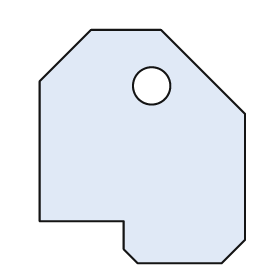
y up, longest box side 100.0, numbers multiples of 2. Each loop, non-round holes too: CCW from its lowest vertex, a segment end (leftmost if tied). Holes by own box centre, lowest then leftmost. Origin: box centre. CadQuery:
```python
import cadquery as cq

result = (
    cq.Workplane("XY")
    .moveTo(-2.0, -50.0)
    .lineTo(34.0, -50.0)
    .lineTo(44.0, -40.0)
    .lineTo(44.0, 14.0)
    .lineTo(8.0, 50.0)
    .lineTo(-22.0, 50.0)
    .lineTo(-44.0, 28.0)
    .lineTo(-44.0, -32.0)
    .lineTo(-8.0, -32.0)
    .lineTo(-8.0, -44.0)
    .close()
    .moveTo(4.0, 26.0)
    .circle(8.0)
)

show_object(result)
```